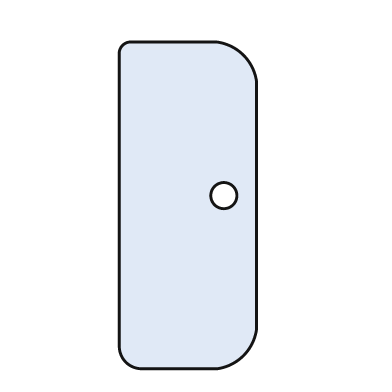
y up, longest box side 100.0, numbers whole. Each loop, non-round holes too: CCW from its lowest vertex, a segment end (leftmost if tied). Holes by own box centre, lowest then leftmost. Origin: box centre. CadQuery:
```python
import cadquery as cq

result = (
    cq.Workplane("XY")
    .moveTo(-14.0, -50.0)
    .lineTo(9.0, -50.0)
    .threePointArc((17.0, -46.0), (21.0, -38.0))
    .lineTo(21.0, 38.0)
    .threePointArc((17.0, 46.0), (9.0, 50.0))
    .lineTo(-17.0, 50.0)
    .threePointArc((-20.0, 49.0), (-21.0, 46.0))
    .lineTo(-21.0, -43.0)
    .threePointArc((-19.0, -48.0), (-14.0, -50.0))
    .close()
    .moveTo(11.0, 3.0)
    .circle(4.0)
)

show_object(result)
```